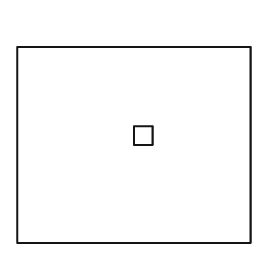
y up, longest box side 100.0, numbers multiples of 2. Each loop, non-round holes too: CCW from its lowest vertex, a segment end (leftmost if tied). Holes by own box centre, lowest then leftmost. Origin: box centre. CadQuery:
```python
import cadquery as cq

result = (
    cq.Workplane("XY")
    .moveTo(-50.0, -42.0)
    .lineTo(50.0, -42.0)
    .lineTo(50.0, 42.0)
    .lineTo(-50.0, 42.0)
    .close()
    .moveTo(0.0, 0.0)
    .lineTo(8.0, 0.0)
    .lineTo(8.0, 8.0)
    .lineTo(0.0, 8.0)
    .close()
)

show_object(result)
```